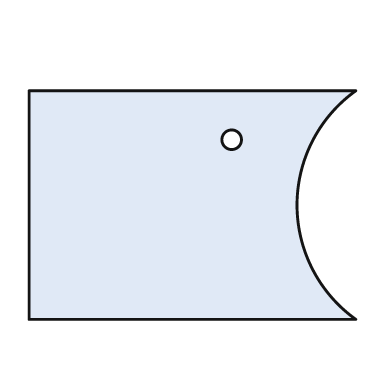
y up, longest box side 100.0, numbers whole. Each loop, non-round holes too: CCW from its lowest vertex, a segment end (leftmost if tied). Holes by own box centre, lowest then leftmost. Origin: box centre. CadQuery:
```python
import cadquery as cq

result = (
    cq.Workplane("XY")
    .moveTo(-50.0, -35.0)
    .lineTo(50.0, -35.0)
    .threePointArc((32.0, 0.0), (50.0, 35.0))
    .lineTo(-50.0, 35.0)
    .close()
    .moveTo(12.0, 20.0)
    .circle(3.0)
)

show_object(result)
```